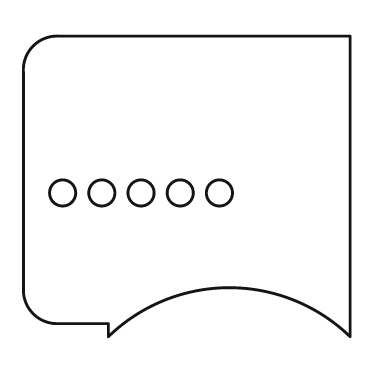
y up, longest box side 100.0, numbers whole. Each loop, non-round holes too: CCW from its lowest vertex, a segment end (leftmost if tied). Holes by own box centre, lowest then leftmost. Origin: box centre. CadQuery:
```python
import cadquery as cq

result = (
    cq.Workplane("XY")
    .moveTo(-24.0, -46.0)
    .threePointArc((13.0, -31.0), (50.0, -46.0))
    .lineTo(50.0, 46.0)
    .lineTo(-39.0, 46.0)
    .threePointArc((-47.0, 43.0), (-50.0, 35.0))
    .lineTo(-50.0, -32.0)
    .threePointArc((-47.0, -39.0), (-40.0, -42.0))
    .lineTo(-24.0, -42.0)
    .close()
    .moveTo(-38.0, -2.0)
    .circle(4.0)
    .moveTo(-26.0, -2.0)
    .circle(4.0)
    .moveTo(-14.0, -2.0)
    .circle(4.0)
    .moveTo(-2.0, -2.0)
    .circle(4.0)
    .moveTo(10.0, -2.0)
    .circle(4.0)
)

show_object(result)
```